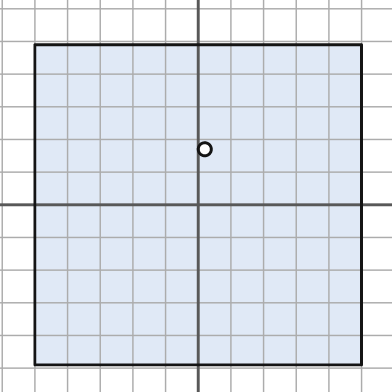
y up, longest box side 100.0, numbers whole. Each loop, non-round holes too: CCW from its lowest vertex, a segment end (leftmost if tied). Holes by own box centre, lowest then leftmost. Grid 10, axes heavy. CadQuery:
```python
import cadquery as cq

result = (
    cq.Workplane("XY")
    .moveTo(-50.0, -49.0)
    .lineTo(50.0, -49.0)
    .lineTo(50.0, 49.0)
    .lineTo(-50.0, 49.0)
    .close()
    .moveTo(2.0, 17.0)
    .circle(2.0)
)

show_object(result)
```